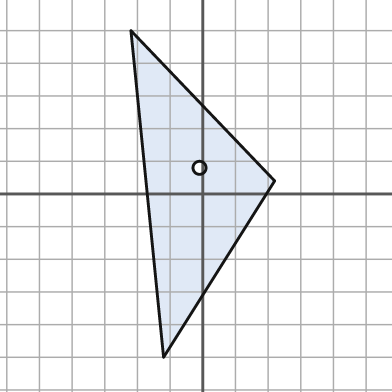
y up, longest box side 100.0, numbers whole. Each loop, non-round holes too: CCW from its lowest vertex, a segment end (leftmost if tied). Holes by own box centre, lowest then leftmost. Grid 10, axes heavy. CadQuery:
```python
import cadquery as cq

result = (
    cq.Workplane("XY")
    .moveTo(-12.0, -50.0)
    .lineTo(22.0, 4.0)
    .lineTo(-22.0, 50.0)
    .close()
    .moveTo(-1.0, 8.0)
    .circle(2.0)
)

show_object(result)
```